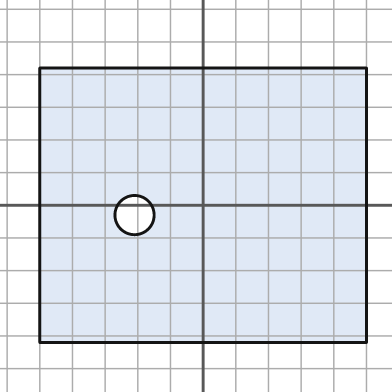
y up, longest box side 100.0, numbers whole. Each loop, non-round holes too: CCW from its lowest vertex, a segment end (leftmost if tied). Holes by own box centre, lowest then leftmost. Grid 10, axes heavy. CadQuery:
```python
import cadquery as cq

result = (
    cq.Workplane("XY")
    .moveTo(-50.0, -42.0)
    .lineTo(50.0, -42.0)
    .lineTo(50.0, 42.0)
    .lineTo(-50.0, 42.0)
    .close()
    .moveTo(-21.0, -3.0)
    .circle(6.0)
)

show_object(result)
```